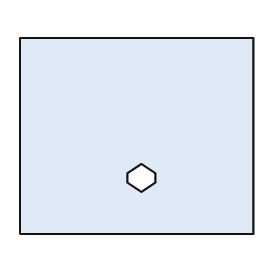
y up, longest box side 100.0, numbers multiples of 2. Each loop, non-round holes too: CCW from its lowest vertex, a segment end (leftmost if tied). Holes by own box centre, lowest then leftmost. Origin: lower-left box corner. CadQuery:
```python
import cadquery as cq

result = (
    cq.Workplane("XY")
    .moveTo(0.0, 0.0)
    .lineTo(100.0, 0.0)
    .lineTo(100.0, 84.0)
    .lineTo(0.0, 84.0)
    .close()
    .moveTo(52.0, 18.0)
    .lineTo(58.0, 22.0)
    .lineTo(58.0, 26.0)
    .lineTo(52.0, 30.0)
    .lineTo(46.0, 26.0)
    .lineTo(46.0, 22.0)
    .close()
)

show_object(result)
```